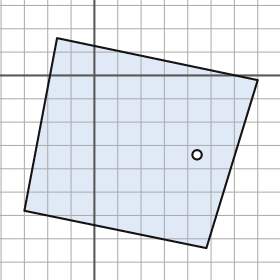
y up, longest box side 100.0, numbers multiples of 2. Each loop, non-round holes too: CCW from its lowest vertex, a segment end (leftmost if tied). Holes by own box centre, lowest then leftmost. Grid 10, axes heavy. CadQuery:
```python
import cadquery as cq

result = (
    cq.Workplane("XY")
    .moveTo(48.0, -74.0)
    .lineTo(70.0, -2.0)
    .lineTo(-16.0, 16.0)
    .lineTo(-30.0, -58.0)
    .close()
    .moveTo(44.0, -34.0)
    .circle(2.0)
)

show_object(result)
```